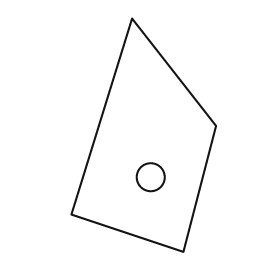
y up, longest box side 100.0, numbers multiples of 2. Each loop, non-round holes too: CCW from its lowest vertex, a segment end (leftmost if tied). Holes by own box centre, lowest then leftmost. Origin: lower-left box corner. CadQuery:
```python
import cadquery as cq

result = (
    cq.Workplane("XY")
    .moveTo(48.0, 0.0)
    .lineTo(62.0, 54.0)
    .lineTo(26.0, 100.0)
    .lineTo(0.0, 16.0)
    .close()
    .moveTo(34.0, 32.0)
    .circle(6.0)
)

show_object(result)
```